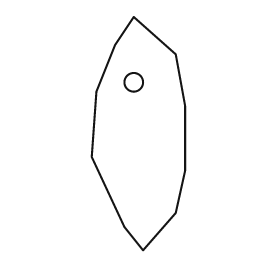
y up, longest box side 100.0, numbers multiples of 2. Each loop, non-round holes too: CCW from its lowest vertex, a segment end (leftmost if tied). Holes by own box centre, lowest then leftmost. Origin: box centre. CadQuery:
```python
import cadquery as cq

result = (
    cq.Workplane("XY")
    .moveTo(2.0, -50.0)
    .lineTo(16.0, -34.0)
    .lineTo(20.0, -16.0)
    .lineTo(20.0, 12.0)
    .lineTo(16.0, 34.0)
    .lineTo(-2.0, 50.0)
    .lineTo(-10.0, 38.0)
    .lineTo(-18.0, 18.0)
    .lineTo(-20.0, -10.0)
    .lineTo(-6.0, -40.0)
    .close()
    .moveTo(-2.0, 22.0)
    .circle(4.0)
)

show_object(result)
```